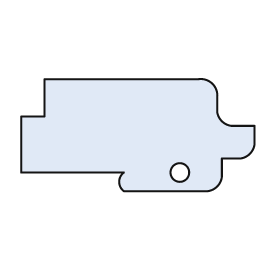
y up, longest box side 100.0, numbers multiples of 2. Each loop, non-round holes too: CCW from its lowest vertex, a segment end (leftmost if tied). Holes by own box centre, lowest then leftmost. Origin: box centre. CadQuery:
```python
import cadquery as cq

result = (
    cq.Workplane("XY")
    .moveTo(-6.0, -24.0)
    .lineTo(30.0, -24.0)
    .threePointArc((34.0, -22.0), (36.0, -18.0))
    .lineTo(36.0, -10.0)
    .lineTo(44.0, -10.0)
    .threePointArc((48.0, -8.0), (50.0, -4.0))
    .lineTo(50.0, 4.0)
    .lineTo(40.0, 4.0)
    .threePointArc((36.0, 6.0), (34.0, 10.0))
    .lineTo(34.0, 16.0)
    .threePointArc((32.0, 22.0), (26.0, 24.0))
    .lineTo(-40.0, 24.0)
    .lineTo(-40.0, 8.0)
    .lineTo(-50.0, 8.0)
    .lineTo(-50.0, -16.0)
    .lineTo(-6.0, -16.0)
    .threePointArc((-8.0, -20.0), (-6.0, -24.0))
    .close()
    .moveTo(18.0, -16.0)
    .circle(4.0)
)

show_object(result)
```